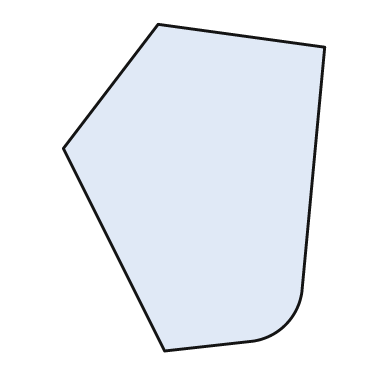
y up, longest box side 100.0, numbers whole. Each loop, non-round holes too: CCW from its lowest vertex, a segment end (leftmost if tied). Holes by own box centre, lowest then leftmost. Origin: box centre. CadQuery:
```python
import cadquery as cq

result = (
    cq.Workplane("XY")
    .moveTo(-9.0, -50.0)
    .lineTo(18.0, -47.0)
    .threePointArc((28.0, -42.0), (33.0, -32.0))
    .lineTo(40.0, 43.0)
    .lineTo(-11.0, 50.0)
    .lineTo(-40.0, 12.0)
    .close()
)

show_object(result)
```